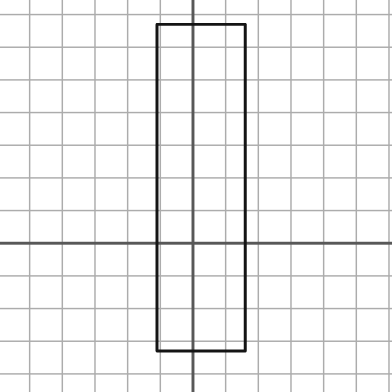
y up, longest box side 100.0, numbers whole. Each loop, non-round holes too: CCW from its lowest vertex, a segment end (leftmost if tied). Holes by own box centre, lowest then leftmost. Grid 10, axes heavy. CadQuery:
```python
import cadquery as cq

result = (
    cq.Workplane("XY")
    .moveTo(-11.0, -33.0)
    .lineTo(16.0, -33.0)
    .lineTo(16.0, 67.0)
    .lineTo(-11.0, 67.0)
    .close()
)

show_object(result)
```